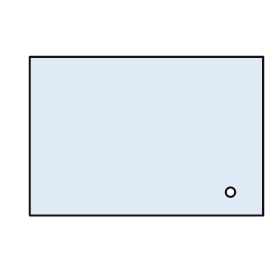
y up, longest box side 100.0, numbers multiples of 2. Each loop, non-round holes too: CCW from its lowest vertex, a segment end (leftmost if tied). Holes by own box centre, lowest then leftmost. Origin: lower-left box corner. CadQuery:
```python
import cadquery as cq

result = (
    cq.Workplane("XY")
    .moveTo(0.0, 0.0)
    .lineTo(100.0, 0.0)
    .lineTo(100.0, 68.0)
    .lineTo(0.0, 68.0)
    .close()
    .moveTo(86.0, 10.0)
    .circle(2.0)
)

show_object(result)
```